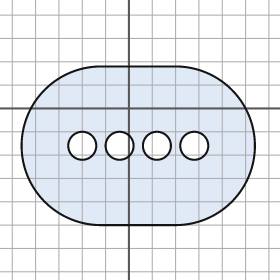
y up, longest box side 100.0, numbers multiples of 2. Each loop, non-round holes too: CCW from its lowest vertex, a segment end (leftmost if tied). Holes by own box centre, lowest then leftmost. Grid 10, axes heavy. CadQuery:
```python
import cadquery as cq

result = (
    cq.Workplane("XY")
    .moveTo(-12.0, -50.0)
    .lineTo(20.0, -50.0)
    .threePointArc((54.0, -16.0), (20.0, 18.0))
    .lineTo(-12.0, 18.0)
    .threePointArc((-46.0, -16.0), (-12.0, -50.0))
    .close()
    .moveTo(-20.0, -16.0)
    .circle(6.0)
    .moveTo(-4.0, -16.0)
    .circle(6.0)
    .moveTo(12.0, -16.0)
    .circle(6.0)
    .moveTo(28.0, -16.0)
    .circle(6.0)
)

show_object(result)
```